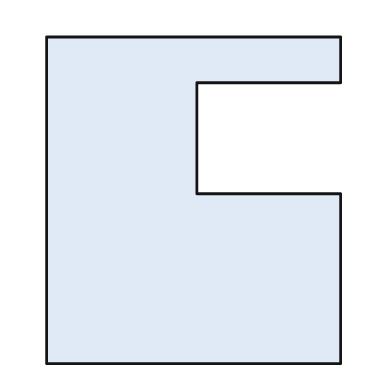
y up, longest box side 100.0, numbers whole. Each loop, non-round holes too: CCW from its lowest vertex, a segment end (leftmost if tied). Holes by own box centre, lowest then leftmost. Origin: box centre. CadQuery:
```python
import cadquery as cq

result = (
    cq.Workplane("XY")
    .moveTo(-45.0, -50.0)
    .lineTo(45.0, -50.0)
    .lineTo(45.0, 2.0)
    .lineTo(1.0, 2.0)
    .lineTo(1.0, 36.0)
    .lineTo(45.0, 36.0)
    .lineTo(45.0, 50.0)
    .lineTo(-45.0, 50.0)
    .close()
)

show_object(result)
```